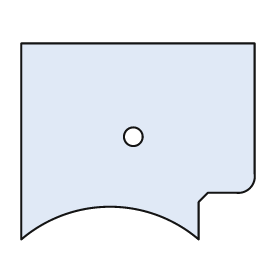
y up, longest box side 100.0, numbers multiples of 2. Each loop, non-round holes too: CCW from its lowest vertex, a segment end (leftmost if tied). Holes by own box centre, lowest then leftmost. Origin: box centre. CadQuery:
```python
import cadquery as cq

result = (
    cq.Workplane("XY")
    .moveTo(-50.0, -42.0)
    .threePointArc((-12.0, -28.0), (26.0, -42.0))
    .lineTo(26.0, -26.0)
    .lineTo(30.0, -22.0)
    .lineTo(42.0, -22.0)
    .threePointArc((48.0, -20.0), (50.0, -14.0))
    .lineTo(50.0, 42.0)
    .lineTo(-50.0, 42.0)
    .close()
    .moveTo(-2.0, 2.0)
    .circle(4.0)
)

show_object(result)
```